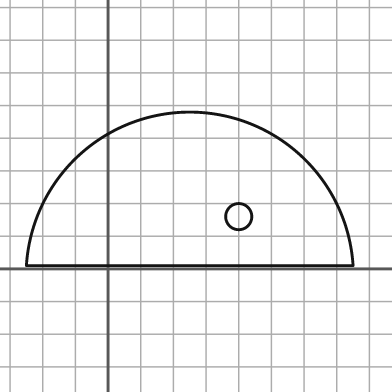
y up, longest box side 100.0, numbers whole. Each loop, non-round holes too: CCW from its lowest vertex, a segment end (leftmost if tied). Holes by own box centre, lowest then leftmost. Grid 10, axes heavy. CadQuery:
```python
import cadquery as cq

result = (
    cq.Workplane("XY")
    .moveTo(-25.0, 1.0)
    .lineTo(75.0, 1.0)
    .threePointArc((25.0, 48.0), (-25.0, 1.0))
    .close()
    .moveTo(40.0, 16.0)
    .circle(4.0)
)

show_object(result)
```